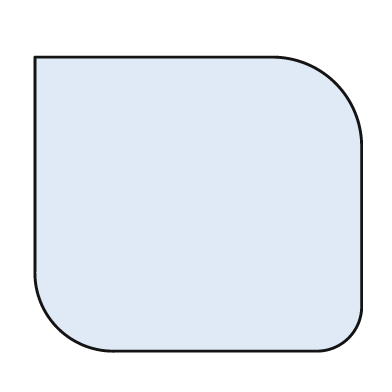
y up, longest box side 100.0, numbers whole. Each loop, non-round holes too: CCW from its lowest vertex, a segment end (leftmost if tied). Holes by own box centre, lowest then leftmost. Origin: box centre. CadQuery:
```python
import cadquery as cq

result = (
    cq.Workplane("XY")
    .moveTo(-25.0, -45.0)
    .lineTo(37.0, -45.0)
    .threePointArc((46.0, -41.0), (50.0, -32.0))
    .lineTo(50.0, 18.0)
    .threePointArc((42.0, 37.0), (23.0, 45.0))
    .lineTo(-50.0, 45.0)
    .lineTo(-50.0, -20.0)
    .threePointArc((-43.0, -38.0), (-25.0, -45.0))
    .close()
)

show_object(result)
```